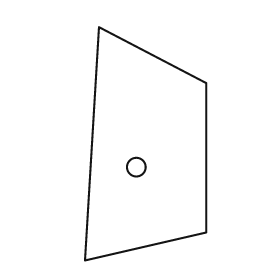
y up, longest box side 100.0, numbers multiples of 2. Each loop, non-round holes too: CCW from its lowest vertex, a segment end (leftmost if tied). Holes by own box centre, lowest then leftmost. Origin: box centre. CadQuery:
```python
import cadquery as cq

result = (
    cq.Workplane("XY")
    .moveTo(-26.0, -50.0)
    .lineTo(26.0, -38.0)
    .lineTo(26.0, 26.0)
    .lineTo(-20.0, 50.0)
    .close()
    .moveTo(-4.0, -10.0)
    .circle(4.0)
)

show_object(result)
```